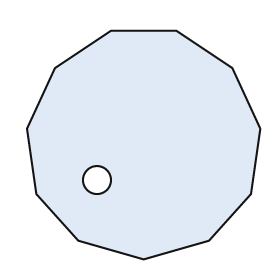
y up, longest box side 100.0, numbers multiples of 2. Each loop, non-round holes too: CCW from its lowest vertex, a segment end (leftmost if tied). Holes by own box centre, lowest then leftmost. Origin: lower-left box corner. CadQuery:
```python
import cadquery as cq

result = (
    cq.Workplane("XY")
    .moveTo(50.0, 0.0)
    .lineTo(78.0, 8.0)
    .lineTo(96.0, 28.0)
    .lineTo(100.0, 56.0)
    .lineTo(88.0, 82.0)
    .lineTo(64.0, 98.0)
    .lineTo(36.0, 98.0)
    .lineTo(12.0, 82.0)
    .lineTo(0.0, 56.0)
    .lineTo(4.0, 28.0)
    .lineTo(22.0, 8.0)
    .close()
    .moveTo(30.0, 34.0)
    .circle(6.0)
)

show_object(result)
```